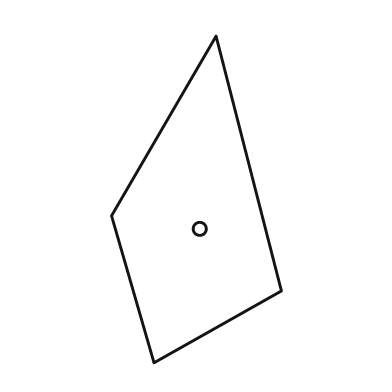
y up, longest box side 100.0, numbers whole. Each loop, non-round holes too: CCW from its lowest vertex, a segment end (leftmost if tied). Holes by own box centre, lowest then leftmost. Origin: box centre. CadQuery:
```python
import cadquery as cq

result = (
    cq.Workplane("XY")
    .moveTo(-13.0, -50.0)
    .lineTo(26.0, -28.0)
    .lineTo(6.0, 50.0)
    .lineTo(-26.0, -5.0)
    .close()
    .moveTo(1.0, -9.0)
    .circle(2.0)
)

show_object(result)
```